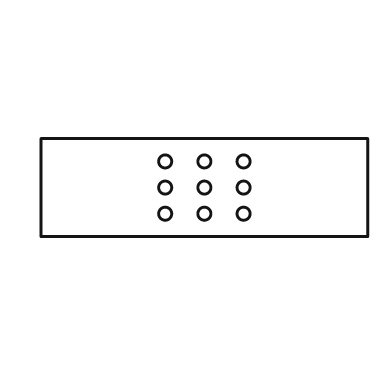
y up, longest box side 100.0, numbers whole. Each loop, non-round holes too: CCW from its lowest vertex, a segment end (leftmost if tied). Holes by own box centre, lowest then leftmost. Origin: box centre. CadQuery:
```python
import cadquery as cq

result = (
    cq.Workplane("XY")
    .moveTo(-50.0, -15.0)
    .lineTo(50.0, -15.0)
    .lineTo(50.0, 15.0)
    .lineTo(-50.0, 15.0)
    .close()
    .moveTo(-12.0, -8.0)
    .circle(2.0)
    .moveTo(0.0, -8.0)
    .circle(2.0)
    .moveTo(12.0, -8.0)
    .circle(2.0)
    .moveTo(-12.0, 0.0)
    .circle(2.0)
    .moveTo(0.0, 0.0)
    .circle(2.0)
    .moveTo(12.0, 0.0)
    .circle(2.0)
    .moveTo(-12.0, 8.0)
    .circle(2.0)
    .moveTo(0.0, 8.0)
    .circle(2.0)
    .moveTo(12.0, 8.0)
    .circle(2.0)
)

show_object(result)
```